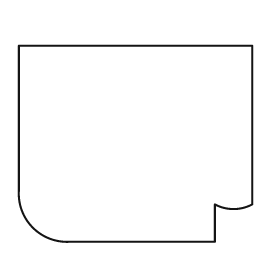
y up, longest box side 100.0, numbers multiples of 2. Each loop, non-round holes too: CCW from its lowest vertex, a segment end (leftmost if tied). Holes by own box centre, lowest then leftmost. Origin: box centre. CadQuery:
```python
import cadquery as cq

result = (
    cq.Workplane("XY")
    .moveTo(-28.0, -42.0)
    .lineTo(34.0, -42.0)
    .lineTo(34.0, -26.0)
    .threePointArc((42.0, -28.0), (50.0, -26.0))
    .lineTo(50.0, 42.0)
    .lineTo(-50.0, 42.0)
    .lineTo(-50.0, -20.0)
    .threePointArc((-44.0, -36.0), (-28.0, -42.0))
    .close()
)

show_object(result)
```